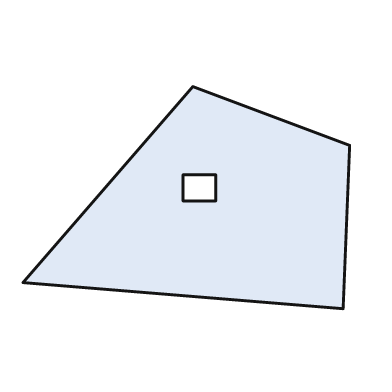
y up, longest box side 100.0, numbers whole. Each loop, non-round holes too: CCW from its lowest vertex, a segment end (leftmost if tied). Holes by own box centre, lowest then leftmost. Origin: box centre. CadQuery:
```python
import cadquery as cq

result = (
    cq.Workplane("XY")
    .moveTo(48.0, -34.0)
    .lineTo(50.0, 16.0)
    .lineTo(2.0, 34.0)
    .lineTo(-50.0, -26.0)
    .close()
    .moveTo(-1.0, -1.0)
    .lineTo(9.0, -1.0)
    .lineTo(9.0, 7.0)
    .lineTo(-1.0, 7.0)
    .close()
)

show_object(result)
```